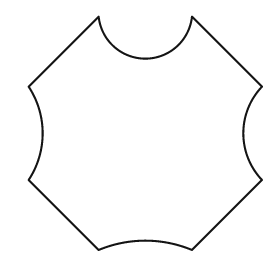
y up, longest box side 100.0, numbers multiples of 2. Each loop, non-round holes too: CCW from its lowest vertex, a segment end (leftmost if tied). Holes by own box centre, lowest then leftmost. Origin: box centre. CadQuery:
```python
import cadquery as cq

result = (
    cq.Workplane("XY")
    .moveTo(-20.0, -50.0)
    .threePointArc((0.0, -46.0), (20.0, -50.0))
    .lineTo(50.0, -20.0)
    .threePointArc((42.0, 0.0), (50.0, 20.0))
    .lineTo(20.0, 50.0)
    .threePointArc((0.0, 32.0), (-20.0, 50.0))
    .lineTo(-50.0, 20.0)
    .threePointArc((-44.0, 0.0), (-50.0, -20.0))
    .close()
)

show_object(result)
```